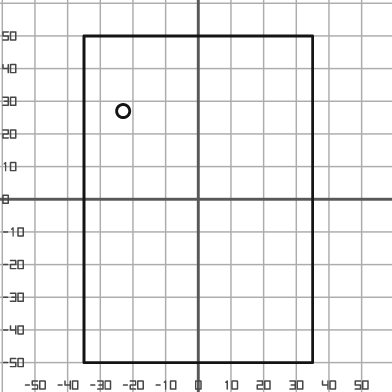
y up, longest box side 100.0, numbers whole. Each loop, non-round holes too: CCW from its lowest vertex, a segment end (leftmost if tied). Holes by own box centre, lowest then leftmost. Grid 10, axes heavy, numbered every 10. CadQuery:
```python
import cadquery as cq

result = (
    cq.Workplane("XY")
    .moveTo(-35.0, -50.0)
    .lineTo(35.0, -50.0)
    .lineTo(35.0, 50.0)
    .lineTo(-35.0, 50.0)
    .close()
    .moveTo(-23.0, 27.0)
    .circle(2.0)
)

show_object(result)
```